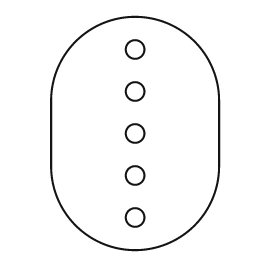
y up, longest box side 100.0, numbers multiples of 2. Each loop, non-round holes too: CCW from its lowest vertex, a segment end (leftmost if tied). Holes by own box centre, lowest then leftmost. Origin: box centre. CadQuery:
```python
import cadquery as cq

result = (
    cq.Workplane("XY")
    .moveTo(-36.0, -14.0)
    .threePointArc((0.0, -50.0), (36.0, -14.0))
    .lineTo(36.0, 14.0)
    .threePointArc((0.0, 50.0), (-36.0, 14.0))
    .close()
    .moveTo(0.0, -36.0)
    .circle(4.0)
    .moveTo(0.0, -18.0)
    .circle(4.0)
    .moveTo(0.0, 0.0)
    .circle(4.0)
    .moveTo(0.0, 18.0)
    .circle(4.0)
    .moveTo(0.0, 36.0)
    .circle(4.0)
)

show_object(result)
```